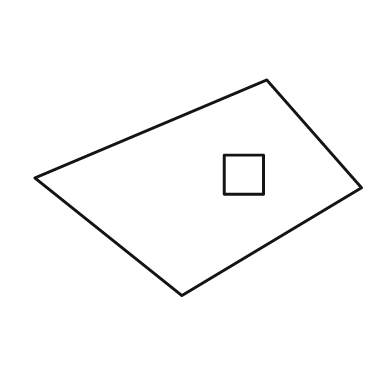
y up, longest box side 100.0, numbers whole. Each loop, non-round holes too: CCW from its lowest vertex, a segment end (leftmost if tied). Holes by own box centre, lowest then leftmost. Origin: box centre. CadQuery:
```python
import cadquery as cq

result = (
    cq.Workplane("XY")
    .moveTo(-5.0, -33.0)
    .lineTo(50.0, 0.0)
    .lineTo(21.0, 33.0)
    .lineTo(-50.0, 3.0)
    .close()
    .moveTo(8.0, -2.0)
    .lineTo(20.0, -2.0)
    .lineTo(20.0, 10.0)
    .lineTo(8.0, 10.0)
    .close()
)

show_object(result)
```